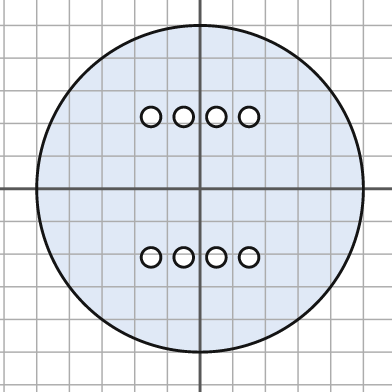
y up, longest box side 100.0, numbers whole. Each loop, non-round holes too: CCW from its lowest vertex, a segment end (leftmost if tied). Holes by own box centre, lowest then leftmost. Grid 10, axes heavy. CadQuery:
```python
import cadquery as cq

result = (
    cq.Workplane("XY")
    .moveTo(0.0, 0.0)
    .circle(50.0)
    .moveTo(-15.0, -21.0)
    .circle(3.0)
    .moveTo(-5.0, -21.0)
    .circle(3.0)
    .moveTo(5.0, -21.0)
    .circle(3.0)
    .moveTo(15.0, -21.0)
    .circle(3.0)
    .moveTo(-15.0, 22.0)
    .circle(3.0)
    .moveTo(-5.0, 22.0)
    .circle(3.0)
    .moveTo(5.0, 22.0)
    .circle(3.0)
    .moveTo(15.0, 22.0)
    .circle(3.0)
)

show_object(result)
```